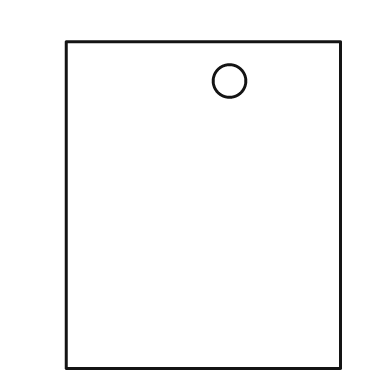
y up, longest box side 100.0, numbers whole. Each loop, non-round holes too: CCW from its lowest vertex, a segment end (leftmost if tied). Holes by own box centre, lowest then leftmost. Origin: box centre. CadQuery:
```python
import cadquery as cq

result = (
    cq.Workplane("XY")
    .moveTo(-42.0, -50.0)
    .lineTo(42.0, -50.0)
    .lineTo(42.0, 50.0)
    .lineTo(-42.0, 50.0)
    .close()
    .moveTo(8.0, 38.0)
    .circle(5.0)
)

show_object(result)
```